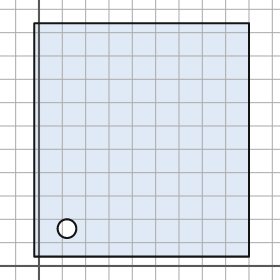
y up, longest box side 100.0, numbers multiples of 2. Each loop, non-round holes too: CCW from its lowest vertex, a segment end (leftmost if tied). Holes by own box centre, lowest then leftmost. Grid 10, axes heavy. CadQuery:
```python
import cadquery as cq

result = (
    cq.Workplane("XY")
    .moveTo(-2.0, 4.0)
    .lineTo(90.0, 4.0)
    .lineTo(90.0, 104.0)
    .lineTo(-2.0, 104.0)
    .close()
    .moveTo(12.0, 16.0)
    .circle(4.0)
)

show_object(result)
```